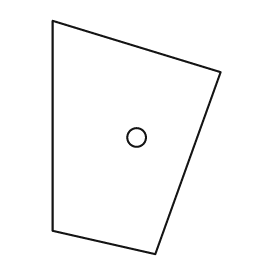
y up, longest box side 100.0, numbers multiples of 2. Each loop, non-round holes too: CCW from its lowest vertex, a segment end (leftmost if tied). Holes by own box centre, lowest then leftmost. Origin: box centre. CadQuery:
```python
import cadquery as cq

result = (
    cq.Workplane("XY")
    .moveTo(8.0, -50.0)
    .lineTo(36.0, 28.0)
    .lineTo(-36.0, 50.0)
    .lineTo(-36.0, -40.0)
    .close()
    .moveTo(0.0, 0.0)
    .circle(4.0)
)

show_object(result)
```